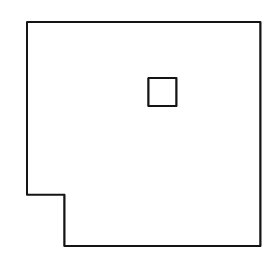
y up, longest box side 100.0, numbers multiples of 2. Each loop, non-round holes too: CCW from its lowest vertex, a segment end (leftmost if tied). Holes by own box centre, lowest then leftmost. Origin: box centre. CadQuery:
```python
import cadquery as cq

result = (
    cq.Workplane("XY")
    .moveTo(-34.0, -48.0)
    .lineTo(50.0, -48.0)
    .lineTo(50.0, 48.0)
    .lineTo(-50.0, 48.0)
    .lineTo(-50.0, -26.0)
    .lineTo(-34.0, -26.0)
    .close()
    .moveTo(2.0, 12.0)
    .lineTo(14.0, 12.0)
    .lineTo(14.0, 24.0)
    .lineTo(2.0, 24.0)
    .close()
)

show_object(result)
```